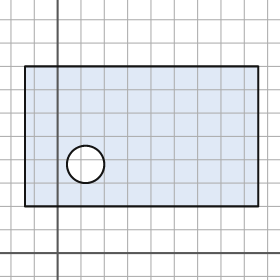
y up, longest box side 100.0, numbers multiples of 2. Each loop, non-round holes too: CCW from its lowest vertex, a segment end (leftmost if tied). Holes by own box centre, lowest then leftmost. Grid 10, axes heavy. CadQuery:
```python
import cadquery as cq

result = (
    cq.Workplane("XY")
    .moveTo(-14.0, 20.0)
    .lineTo(86.0, 20.0)
    .lineTo(86.0, 80.0)
    .lineTo(-14.0, 80.0)
    .close()
    .moveTo(12.0, 38.0)
    .circle(8.0)
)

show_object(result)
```